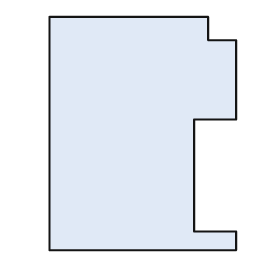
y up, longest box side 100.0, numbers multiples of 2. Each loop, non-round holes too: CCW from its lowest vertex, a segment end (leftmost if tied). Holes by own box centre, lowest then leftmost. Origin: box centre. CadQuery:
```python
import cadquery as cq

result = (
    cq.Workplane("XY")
    .moveTo(-40.0, -50.0)
    .lineTo(40.0, -50.0)
    .lineTo(40.0, -42.0)
    .lineTo(22.0, -42.0)
    .lineTo(22.0, 6.0)
    .lineTo(40.0, 6.0)
    .lineTo(40.0, 40.0)
    .lineTo(28.0, 40.0)
    .lineTo(28.0, 50.0)
    .lineTo(-40.0, 50.0)
    .close()
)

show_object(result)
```